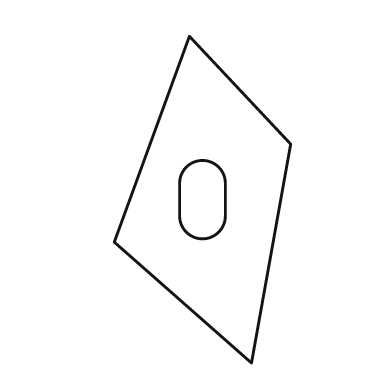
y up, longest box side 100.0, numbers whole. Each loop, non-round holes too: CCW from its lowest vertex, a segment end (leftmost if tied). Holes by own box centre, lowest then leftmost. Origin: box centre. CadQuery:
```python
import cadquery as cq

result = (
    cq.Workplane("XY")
    .moveTo(15.0, -50.0)
    .lineTo(27.0, 17.0)
    .lineTo(-4.0, 50.0)
    .lineTo(-27.0, -13.0)
    .close()
    .moveTo(-7.0, -5.0)
    .threePointArc((0.0, -12.0), (7.0, -5.0))
    .lineTo(7.0, 5.0)
    .threePointArc((0.0, 12.0), (-7.0, 5.0))
    .close()
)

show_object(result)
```